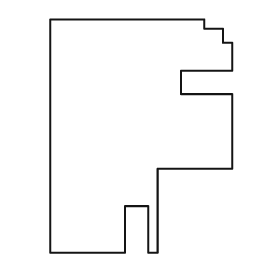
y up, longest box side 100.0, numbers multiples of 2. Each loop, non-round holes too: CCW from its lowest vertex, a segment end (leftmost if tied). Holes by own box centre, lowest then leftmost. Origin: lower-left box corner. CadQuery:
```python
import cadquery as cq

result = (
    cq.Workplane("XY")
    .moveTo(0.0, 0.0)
    .lineTo(32.0, 0.0)
    .lineTo(32.0, 20.0)
    .lineTo(42.0, 20.0)
    .lineTo(42.0, 0.0)
    .lineTo(46.0, 0.0)
    .lineTo(46.0, 36.0)
    .lineTo(78.0, 36.0)
    .lineTo(78.0, 68.0)
    .lineTo(56.0, 68.0)
    .lineTo(56.0, 78.0)
    .lineTo(78.0, 78.0)
    .lineTo(78.0, 90.0)
    .lineTo(74.0, 90.0)
    .lineTo(74.0, 96.0)
    .lineTo(66.0, 96.0)
    .lineTo(66.0, 100.0)
    .lineTo(0.0, 100.0)
    .close()
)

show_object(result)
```